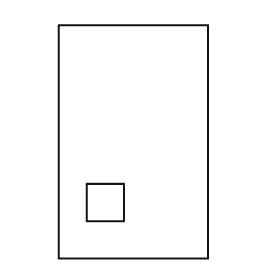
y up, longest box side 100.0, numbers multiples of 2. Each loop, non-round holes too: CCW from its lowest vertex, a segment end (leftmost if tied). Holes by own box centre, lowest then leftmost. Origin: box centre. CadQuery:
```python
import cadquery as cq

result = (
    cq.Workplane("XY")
    .moveTo(-32.0, -50.0)
    .lineTo(32.0, -50.0)
    .lineTo(32.0, 50.0)
    .lineTo(-32.0, 50.0)
    .close()
    .moveTo(-20.0, -34.0)
    .lineTo(-4.0, -34.0)
    .lineTo(-4.0, -18.0)
    .lineTo(-20.0, -18.0)
    .close()
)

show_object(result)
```